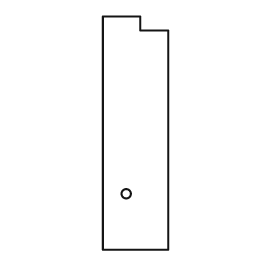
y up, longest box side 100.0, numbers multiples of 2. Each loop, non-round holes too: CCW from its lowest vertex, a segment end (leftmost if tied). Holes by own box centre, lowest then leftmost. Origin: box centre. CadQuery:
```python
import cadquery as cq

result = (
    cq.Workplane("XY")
    .moveTo(-14.0, -50.0)
    .lineTo(14.0, -50.0)
    .lineTo(14.0, 44.0)
    .lineTo(2.0, 44.0)
    .lineTo(2.0, 50.0)
    .lineTo(-14.0, 50.0)
    .close()
    .moveTo(-4.0, -26.0)
    .circle(2.0)
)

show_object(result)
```